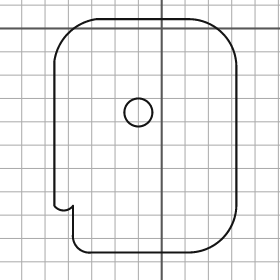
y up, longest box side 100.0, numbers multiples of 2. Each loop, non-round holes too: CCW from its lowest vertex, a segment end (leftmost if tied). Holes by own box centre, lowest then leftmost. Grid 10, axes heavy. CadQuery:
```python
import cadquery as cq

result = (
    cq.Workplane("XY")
    .moveTo(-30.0, -96.0)
    .lineTo(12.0, -96.0)
    .threePointArc((26.0, -90.0), (32.0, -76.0))
    .lineTo(32.0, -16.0)
    .threePointArc((26.0, -2.0), (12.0, 4.0))
    .lineTo(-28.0, 4.0)
    .threePointArc((-40.0, -2.0), (-46.0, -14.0))
    .lineTo(-46.0, -76.0)
    .threePointArc((-42.0, -78.0), (-38.0, -76.0))
    .lineTo(-38.0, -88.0)
    .threePointArc((-36.0, -94.0), (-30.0, -96.0))
    .close()
    .moveTo(-10.0, -36.0)
    .circle(6.0)
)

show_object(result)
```